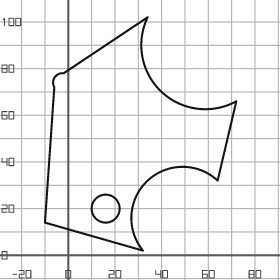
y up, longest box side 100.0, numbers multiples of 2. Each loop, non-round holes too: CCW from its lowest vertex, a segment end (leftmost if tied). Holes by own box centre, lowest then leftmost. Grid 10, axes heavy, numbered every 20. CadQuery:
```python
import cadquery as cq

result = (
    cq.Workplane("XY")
    .moveTo(32.0, 2.0)
    .threePointArc((34.0, 32.0), (64.0, 32.0))
    .lineTo(72.0, 66.0)
    .threePointArc((40.0, 70.0), (34.0, 102.0))
    .lineTo(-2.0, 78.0)
    .threePointArc((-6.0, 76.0), (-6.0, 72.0))
    .lineTo(-10.0, 14.0)
    .close()
    .moveTo(16.0, 20.0)
    .circle(6.0)
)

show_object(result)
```